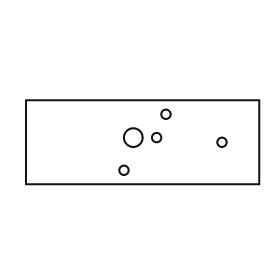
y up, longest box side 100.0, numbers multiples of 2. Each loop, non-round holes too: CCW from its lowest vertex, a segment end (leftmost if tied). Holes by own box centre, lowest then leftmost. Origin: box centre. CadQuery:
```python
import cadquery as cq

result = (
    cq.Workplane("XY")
    .moveTo(-50.0, -18.0)
    .lineTo(50.0, -18.0)
    .lineTo(50.0, 18.0)
    .lineTo(-50.0, 18.0)
    .close()
    .moveTo(-8.0, -12.0)
    .circle(2.0)
    .moveTo(34.0, 0.0)
    .circle(2.0)
    .moveTo(-4.0, 2.0)
    .circle(4.0)
    .moveTo(6.0, 2.0)
    .circle(2.0)
    .moveTo(10.0, 12.0)
    .circle(2.0)
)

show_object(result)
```